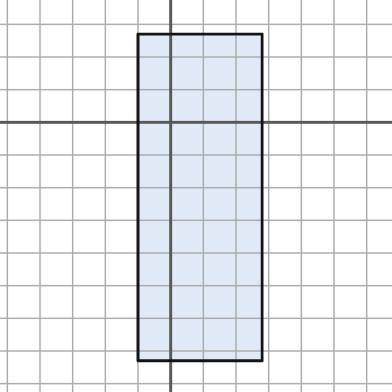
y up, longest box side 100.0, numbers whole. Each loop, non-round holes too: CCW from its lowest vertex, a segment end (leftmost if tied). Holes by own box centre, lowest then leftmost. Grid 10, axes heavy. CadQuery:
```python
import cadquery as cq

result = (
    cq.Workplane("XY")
    .moveTo(-10.0, -73.0)
    .lineTo(28.0, -73.0)
    .lineTo(28.0, 27.0)
    .lineTo(-10.0, 27.0)
    .close()
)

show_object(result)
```